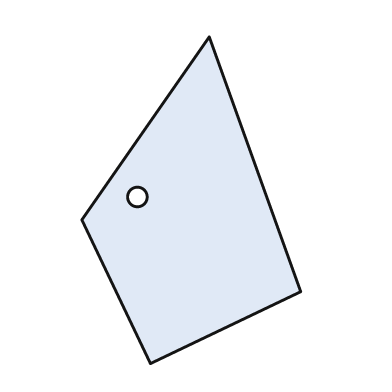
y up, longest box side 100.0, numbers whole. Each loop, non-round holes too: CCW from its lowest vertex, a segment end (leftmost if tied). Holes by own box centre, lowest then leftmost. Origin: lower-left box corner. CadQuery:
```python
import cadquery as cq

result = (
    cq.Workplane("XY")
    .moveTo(21.0, 0.0)
    .lineTo(67.0, 22.0)
    .lineTo(39.0, 100.0)
    .lineTo(0.0, 44.0)
    .close()
    .moveTo(17.0, 51.0)
    .circle(3.0)
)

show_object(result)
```